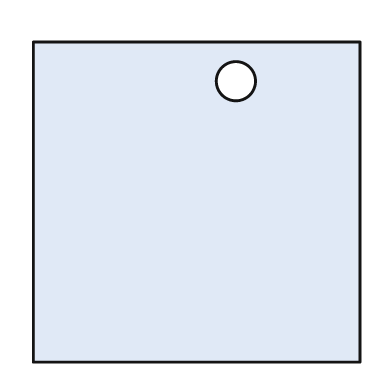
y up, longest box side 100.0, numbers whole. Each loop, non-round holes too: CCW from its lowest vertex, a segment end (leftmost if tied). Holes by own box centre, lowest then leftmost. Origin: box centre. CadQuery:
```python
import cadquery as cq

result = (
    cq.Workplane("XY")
    .moveTo(-50.0, -49.0)
    .lineTo(50.0, -49.0)
    .lineTo(50.0, 49.0)
    .lineTo(-50.0, 49.0)
    .close()
    .moveTo(12.0, 37.0)
    .circle(6.0)
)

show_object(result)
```